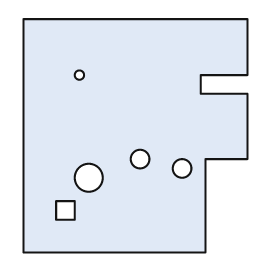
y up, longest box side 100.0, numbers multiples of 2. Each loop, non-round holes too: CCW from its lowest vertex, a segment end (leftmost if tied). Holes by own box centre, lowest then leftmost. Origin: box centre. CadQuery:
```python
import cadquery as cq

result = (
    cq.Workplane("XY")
    .moveTo(-48.0, -50.0)
    .lineTo(30.0, -50.0)
    .lineTo(30.0, -10.0)
    .lineTo(48.0, -10.0)
    .lineTo(48.0, 18.0)
    .lineTo(28.0, 18.0)
    .lineTo(28.0, 26.0)
    .lineTo(48.0, 26.0)
    .lineTo(48.0, 50.0)
    .lineTo(-48.0, 50.0)
    .close()
    .moveTo(-34.0, -36.0)
    .lineTo(-26.0, -36.0)
    .lineTo(-26.0, -28.0)
    .lineTo(-34.0, -28.0)
    .close()
    .moveTo(-20.0, -18.0)
    .circle(6.0)
    .moveTo(20.0, -14.0)
    .circle(4.0)
    .moveTo(2.0, -10.0)
    .circle(4.0)
    .moveTo(-24.0, 26.0)
    .circle(2.0)
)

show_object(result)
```